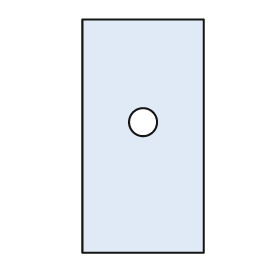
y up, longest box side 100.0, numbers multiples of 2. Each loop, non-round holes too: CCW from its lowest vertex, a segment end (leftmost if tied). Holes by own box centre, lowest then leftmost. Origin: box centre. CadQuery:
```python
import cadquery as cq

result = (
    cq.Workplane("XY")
    .moveTo(-26.0, -50.0)
    .lineTo(26.0, -50.0)
    .lineTo(26.0, 50.0)
    .lineTo(-26.0, 50.0)
    .close()
    .moveTo(0.0, 6.0)
    .circle(6.0)
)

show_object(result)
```